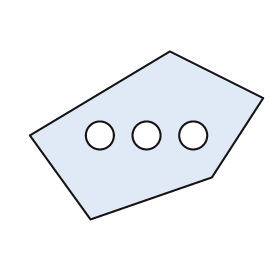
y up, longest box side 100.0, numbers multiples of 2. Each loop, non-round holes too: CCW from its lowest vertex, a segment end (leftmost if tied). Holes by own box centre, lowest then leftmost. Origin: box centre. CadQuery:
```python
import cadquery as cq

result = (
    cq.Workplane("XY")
    .moveTo(-24.0, -36.0)
    .lineTo(28.0, -18.0)
    .lineTo(50.0, 16.0)
    .lineTo(10.0, 36.0)
    .lineTo(-50.0, 0.0)
    .close()
    .moveTo(-20.0, 0.0)
    .circle(6.0)
    .moveTo(0.0, 0.0)
    .circle(6.0)
    .moveTo(20.0, 0.0)
    .circle(6.0)
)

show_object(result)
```